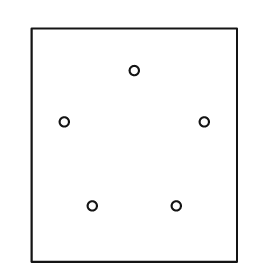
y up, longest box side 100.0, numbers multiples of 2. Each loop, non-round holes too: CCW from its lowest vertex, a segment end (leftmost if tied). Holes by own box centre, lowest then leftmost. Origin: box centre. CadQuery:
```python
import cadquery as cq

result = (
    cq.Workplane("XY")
    .moveTo(-44.0, -50.0)
    .lineTo(44.0, -50.0)
    .lineTo(44.0, 50.0)
    .lineTo(-44.0, 50.0)
    .close()
    .moveTo(-18.0, -26.0)
    .circle(2.0)
    .moveTo(18.0, -26.0)
    .circle(2.0)
    .moveTo(-30.0, 10.0)
    .circle(2.0)
    .moveTo(30.0, 10.0)
    .circle(2.0)
    .moveTo(0.0, 32.0)
    .circle(2.0)
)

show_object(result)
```